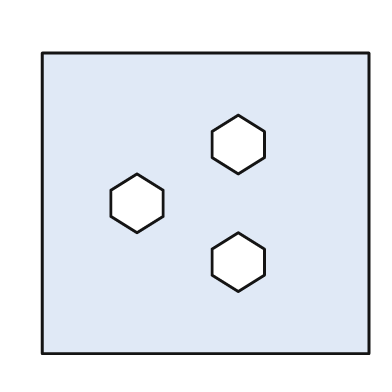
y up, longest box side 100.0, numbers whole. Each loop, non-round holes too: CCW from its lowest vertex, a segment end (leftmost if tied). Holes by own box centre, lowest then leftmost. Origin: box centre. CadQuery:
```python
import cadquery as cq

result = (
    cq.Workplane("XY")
    .moveTo(-50.0, -46.0)
    .lineTo(50.0, -46.0)
    .lineTo(50.0, 46.0)
    .lineTo(-50.0, 46.0)
    .close()
    .moveTo(10.0, -27.0)
    .lineTo(18.0, -22.0)
    .lineTo(18.0, -14.0)
    .lineTo(10.0, -9.0)
    .lineTo(2.0, -14.0)
    .lineTo(2.0, -22.0)
    .close()
    .moveTo(-21.0, -9.0)
    .lineTo(-13.0, -4.0)
    .lineTo(-13.0, 4.0)
    .lineTo(-21.0, 9.0)
    .lineTo(-29.0, 4.0)
    .lineTo(-29.0, -4.0)
    .close()
    .moveTo(10.0, 9.0)
    .lineTo(18.0, 14.0)
    .lineTo(18.0, 22.0)
    .lineTo(10.0, 27.0)
    .lineTo(2.0, 22.0)
    .lineTo(2.0, 14.0)
    .close()
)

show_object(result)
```